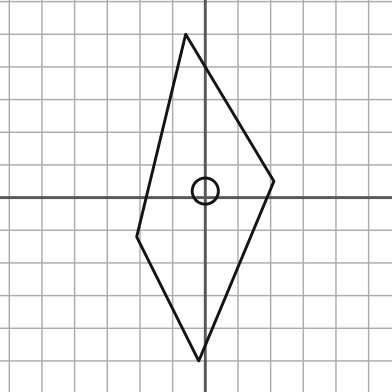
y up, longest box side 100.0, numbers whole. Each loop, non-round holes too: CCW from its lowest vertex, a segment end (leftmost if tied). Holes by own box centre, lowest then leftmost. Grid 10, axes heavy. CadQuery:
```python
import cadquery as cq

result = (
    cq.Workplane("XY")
    .moveTo(-2.0, -50.0)
    .lineTo(21.0, 5.0)
    .lineTo(-6.0, 50.0)
    .lineTo(-21.0, -12.0)
    .close()
    .moveTo(0.0, 2.0)
    .circle(4.0)
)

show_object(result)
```